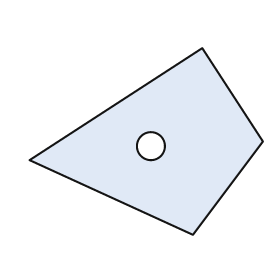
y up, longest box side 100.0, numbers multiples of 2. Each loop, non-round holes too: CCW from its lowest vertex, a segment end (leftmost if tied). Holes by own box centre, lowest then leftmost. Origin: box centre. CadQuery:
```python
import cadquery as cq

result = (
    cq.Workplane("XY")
    .moveTo(20.0, -40.0)
    .lineTo(50.0, 0.0)
    .lineTo(24.0, 40.0)
    .lineTo(-50.0, -8.0)
    .close()
    .moveTo(2.0, -2.0)
    .circle(6.0)
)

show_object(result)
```